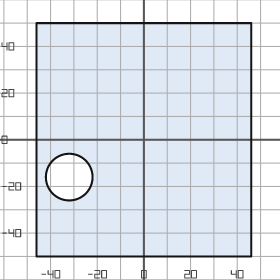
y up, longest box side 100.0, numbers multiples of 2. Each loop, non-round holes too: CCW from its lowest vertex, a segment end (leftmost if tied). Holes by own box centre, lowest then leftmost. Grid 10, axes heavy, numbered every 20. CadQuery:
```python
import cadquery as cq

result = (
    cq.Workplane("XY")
    .moveTo(-46.0, -50.0)
    .lineTo(46.0, -50.0)
    .lineTo(46.0, 50.0)
    .lineTo(-46.0, 50.0)
    .close()
    .moveTo(-32.0, -16.0)
    .circle(10.0)
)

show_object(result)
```